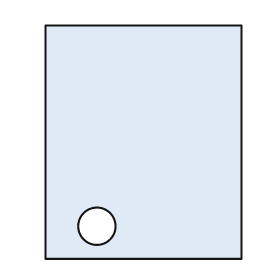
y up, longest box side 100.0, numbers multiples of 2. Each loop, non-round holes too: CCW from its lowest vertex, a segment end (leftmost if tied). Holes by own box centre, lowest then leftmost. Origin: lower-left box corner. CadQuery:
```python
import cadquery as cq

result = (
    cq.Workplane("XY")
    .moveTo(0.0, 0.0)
    .lineTo(84.0, 0.0)
    .lineTo(84.0, 100.0)
    .lineTo(0.0, 100.0)
    .close()
    .moveTo(22.0, 14.0)
    .circle(8.0)
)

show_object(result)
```